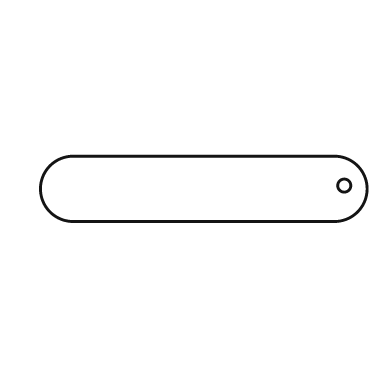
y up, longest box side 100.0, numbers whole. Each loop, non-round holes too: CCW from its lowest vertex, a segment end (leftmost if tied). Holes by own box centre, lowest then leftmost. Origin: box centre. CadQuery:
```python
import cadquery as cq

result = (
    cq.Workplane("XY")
    .moveTo(-40.0, -10.0)
    .lineTo(40.0, -10.0)
    .threePointArc((50.0, 0.0), (40.0, 10.0))
    .lineTo(-40.0, 10.0)
    .threePointArc((-50.0, 0.0), (-40.0, -10.0))
    .close()
    .moveTo(43.0, 1.0)
    .circle(2.0)
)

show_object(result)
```